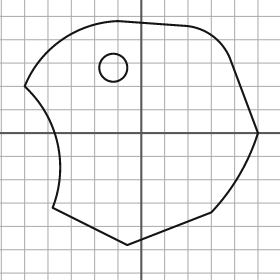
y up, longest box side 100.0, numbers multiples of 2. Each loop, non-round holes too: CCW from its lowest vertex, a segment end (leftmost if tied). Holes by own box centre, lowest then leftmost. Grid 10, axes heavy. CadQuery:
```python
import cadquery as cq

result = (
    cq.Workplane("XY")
    .moveTo(-6.0, -48.0)
    .lineTo(30.0, -34.0)
    .threePointArc((42.0, -18.0), (50.0, 0.0))
    .lineTo(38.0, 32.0)
    .threePointArc((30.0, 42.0), (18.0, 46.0))
    .lineTo(-10.0, 48.0)
    .threePointArc((-34.0, 40.0), (-50.0, 20.0))
    .threePointArc((-36.0, -4.0), (-38.0, -32.0))
    .close()
    .moveTo(-12.0, 28.0)
    .circle(6.0)
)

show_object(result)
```